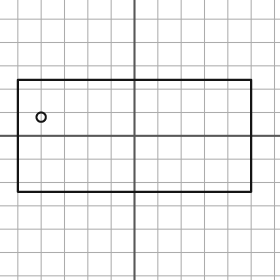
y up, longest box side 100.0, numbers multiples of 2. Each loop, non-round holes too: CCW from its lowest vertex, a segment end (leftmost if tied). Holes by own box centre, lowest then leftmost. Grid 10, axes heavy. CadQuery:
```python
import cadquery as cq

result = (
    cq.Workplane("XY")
    .moveTo(-50.0, -24.0)
    .lineTo(50.0, -24.0)
    .lineTo(50.0, 24.0)
    .lineTo(-50.0, 24.0)
    .close()
    .moveTo(-40.0, 8.0)
    .circle(2.0)
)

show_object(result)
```